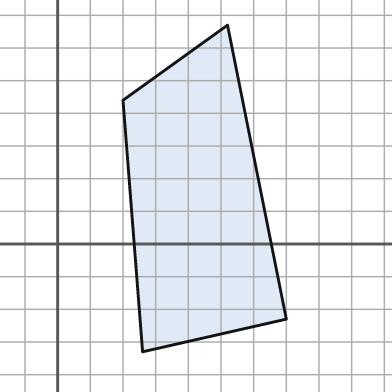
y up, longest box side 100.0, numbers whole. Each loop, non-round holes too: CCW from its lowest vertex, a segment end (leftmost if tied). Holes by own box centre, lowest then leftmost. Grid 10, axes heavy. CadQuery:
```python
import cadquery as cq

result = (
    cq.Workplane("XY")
    .moveTo(26.0, -33.0)
    .lineTo(70.0, -23.0)
    .lineTo(52.0, 67.0)
    .lineTo(20.0, 44.0)
    .close()
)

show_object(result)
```